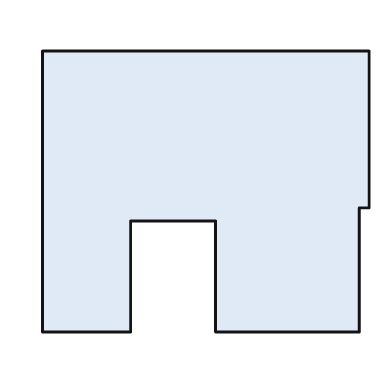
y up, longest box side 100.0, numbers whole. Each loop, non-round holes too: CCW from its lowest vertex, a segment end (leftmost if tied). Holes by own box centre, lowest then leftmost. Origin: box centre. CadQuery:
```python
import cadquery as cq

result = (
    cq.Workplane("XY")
    .moveTo(-50.0, -43.0)
    .lineTo(-23.0, -43.0)
    .lineTo(-23.0, -9.0)
    .lineTo(3.0, -9.0)
    .lineTo(3.0, -43.0)
    .lineTo(47.0, -43.0)
    .lineTo(47.0, -5.0)
    .lineTo(50.0, -5.0)
    .lineTo(50.0, 43.0)
    .lineTo(-50.0, 43.0)
    .close()
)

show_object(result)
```